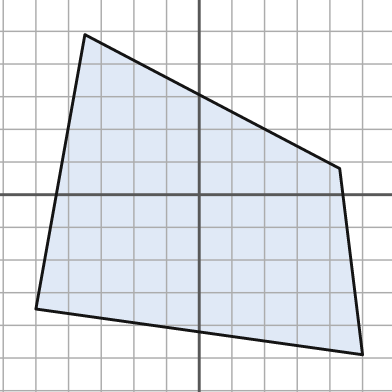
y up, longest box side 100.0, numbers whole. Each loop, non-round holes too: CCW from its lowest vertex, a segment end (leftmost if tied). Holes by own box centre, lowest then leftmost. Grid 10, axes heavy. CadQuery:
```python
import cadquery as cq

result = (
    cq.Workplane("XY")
    .moveTo(50.0, -49.0)
    .lineTo(43.0, 8.0)
    .lineTo(-35.0, 49.0)
    .lineTo(-50.0, -35.0)
    .close()
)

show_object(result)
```